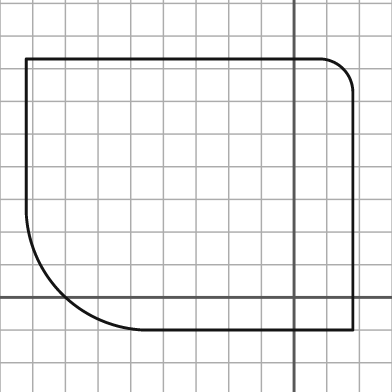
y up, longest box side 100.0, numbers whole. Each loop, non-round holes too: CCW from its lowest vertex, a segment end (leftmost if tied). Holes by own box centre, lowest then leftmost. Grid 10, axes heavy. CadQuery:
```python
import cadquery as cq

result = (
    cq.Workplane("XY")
    .moveTo(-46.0, -10.0)
    .lineTo(18.0, -10.0)
    .lineTo(18.0, 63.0)
    .threePointArc((15.0, 70.0), (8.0, 73.0))
    .lineTo(-82.0, 73.0)
    .lineTo(-82.0, 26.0)
    .threePointArc((-71.0, 1.0), (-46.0, -10.0))
    .close()
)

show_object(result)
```